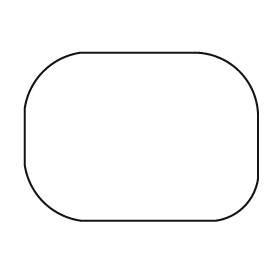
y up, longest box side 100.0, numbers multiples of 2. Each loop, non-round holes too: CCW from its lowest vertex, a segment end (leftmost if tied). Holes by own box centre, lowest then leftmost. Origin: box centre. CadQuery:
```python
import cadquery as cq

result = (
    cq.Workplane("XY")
    .moveTo(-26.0, -36.0)
    .lineTo(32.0, -36.0)
    .threePointArc((44.0, -30.0), (50.0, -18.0))
    .lineTo(50.0, 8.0)
    .threePointArc((42.0, 28.0), (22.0, 36.0))
    .lineTo(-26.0, 36.0)
    .threePointArc((-42.0, 28.0), (-50.0, 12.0))
    .lineTo(-50.0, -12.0)
    .threePointArc((-42.0, -28.0), (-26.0, -36.0))
    .close()
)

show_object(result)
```